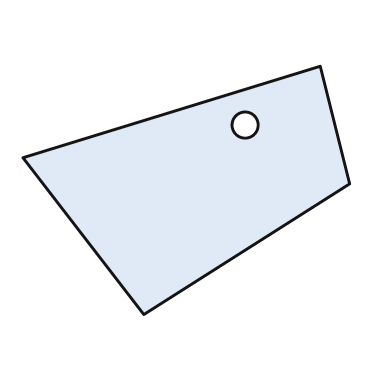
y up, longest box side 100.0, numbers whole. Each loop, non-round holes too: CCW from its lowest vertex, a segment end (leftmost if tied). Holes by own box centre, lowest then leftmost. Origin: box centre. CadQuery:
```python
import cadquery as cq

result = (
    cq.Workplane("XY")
    .moveTo(-13.0, -38.0)
    .lineTo(50.0, 2.0)
    .lineTo(41.0, 38.0)
    .lineTo(-50.0, 10.0)
    .close()
    .moveTo(18.0, 20.0)
    .circle(4.0)
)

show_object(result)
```